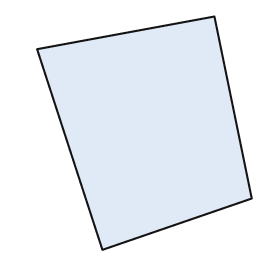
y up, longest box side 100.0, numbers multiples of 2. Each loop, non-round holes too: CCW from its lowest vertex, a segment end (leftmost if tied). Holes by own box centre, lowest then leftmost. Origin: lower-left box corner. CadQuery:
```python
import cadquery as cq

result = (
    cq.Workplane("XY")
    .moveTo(28.0, 0.0)
    .lineTo(92.0, 22.0)
    .lineTo(76.0, 100.0)
    .lineTo(0.0, 86.0)
    .close()
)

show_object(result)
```